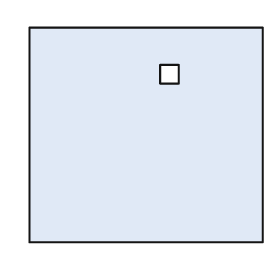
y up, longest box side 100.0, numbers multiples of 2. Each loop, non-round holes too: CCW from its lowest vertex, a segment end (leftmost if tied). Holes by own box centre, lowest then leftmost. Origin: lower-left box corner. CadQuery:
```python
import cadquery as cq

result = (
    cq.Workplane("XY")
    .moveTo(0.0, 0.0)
    .lineTo(100.0, 0.0)
    .lineTo(100.0, 92.0)
    .lineTo(0.0, 92.0)
    .close()
    .moveTo(56.0, 68.0)
    .lineTo(64.0, 68.0)
    .lineTo(64.0, 76.0)
    .lineTo(56.0, 76.0)
    .close()
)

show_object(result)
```